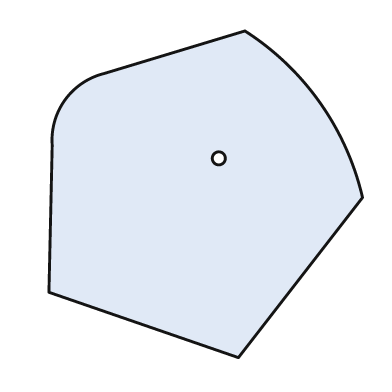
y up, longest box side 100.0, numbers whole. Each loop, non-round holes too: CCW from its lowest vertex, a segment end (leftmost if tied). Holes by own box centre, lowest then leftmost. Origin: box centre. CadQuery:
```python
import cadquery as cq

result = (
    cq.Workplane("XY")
    .moveTo(10.0, -50.0)
    .lineTo(48.0, -1.0)
    .threePointArc((35.0, 28.0), (12.0, 50.0))
    .lineTo(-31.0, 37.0)
    .threePointArc((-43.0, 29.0), (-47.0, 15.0))
    .lineTo(-48.0, -30.0)
    .close()
    .moveTo(4.0, 11.0)
    .circle(2.0)
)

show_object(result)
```